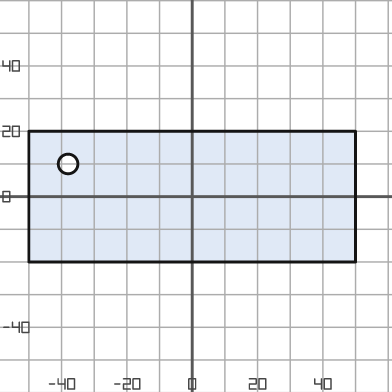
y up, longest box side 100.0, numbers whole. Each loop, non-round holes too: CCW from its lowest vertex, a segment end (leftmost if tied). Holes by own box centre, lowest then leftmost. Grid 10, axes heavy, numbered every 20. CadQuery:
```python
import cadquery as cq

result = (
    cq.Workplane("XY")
    .moveTo(-50.0, -20.0)
    .lineTo(50.0, -20.0)
    .lineTo(50.0, 20.0)
    .lineTo(-50.0, 20.0)
    .close()
    .moveTo(-38.0, 10.0)
    .circle(3.0)
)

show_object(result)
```